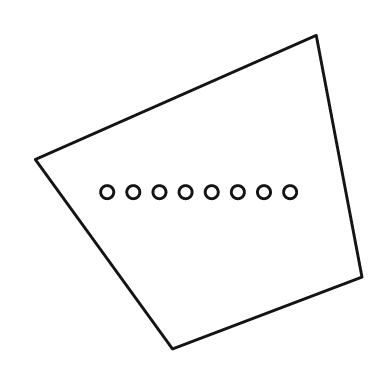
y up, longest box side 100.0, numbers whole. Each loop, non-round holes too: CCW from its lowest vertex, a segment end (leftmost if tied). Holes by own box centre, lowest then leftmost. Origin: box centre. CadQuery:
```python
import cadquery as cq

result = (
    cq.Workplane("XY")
    .moveTo(-8.0, -48.0)
    .lineTo(50.0, -26.0)
    .lineTo(36.0, 48.0)
    .lineTo(-50.0, 10.0)
    .close()
    .moveTo(-28.0, 0.0)
    .circle(2.0)
    .moveTo(-20.0, 0.0)
    .circle(2.0)
    .moveTo(-12.0, 0.0)
    .circle(2.0)
    .moveTo(-4.0, 0.0)
    .circle(2.0)
    .moveTo(4.0, 0.0)
    .circle(2.0)
    .moveTo(12.0, 0.0)
    .circle(2.0)
    .moveTo(20.0, 0.0)
    .circle(2.0)
    .moveTo(28.0, 0.0)
    .circle(2.0)
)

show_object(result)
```